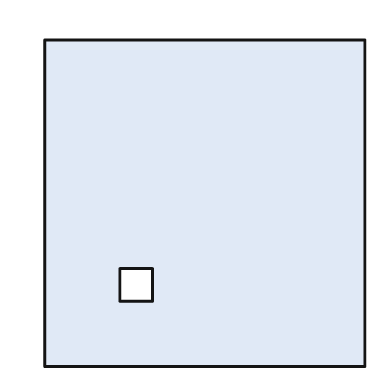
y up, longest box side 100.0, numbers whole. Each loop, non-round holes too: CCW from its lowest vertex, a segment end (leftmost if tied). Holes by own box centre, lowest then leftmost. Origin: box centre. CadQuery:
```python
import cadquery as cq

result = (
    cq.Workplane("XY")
    .moveTo(-49.0, -50.0)
    .lineTo(49.0, -50.0)
    .lineTo(49.0, 50.0)
    .lineTo(-49.0, 50.0)
    .close()
    .moveTo(-26.0, -30.0)
    .lineTo(-16.0, -30.0)
    .lineTo(-16.0, -20.0)
    .lineTo(-26.0, -20.0)
    .close()
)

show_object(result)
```